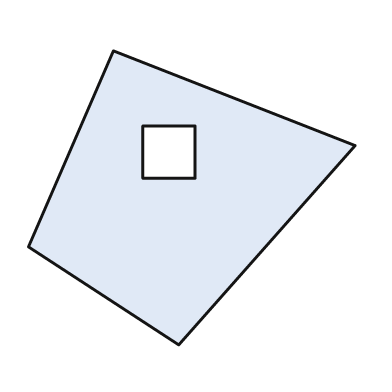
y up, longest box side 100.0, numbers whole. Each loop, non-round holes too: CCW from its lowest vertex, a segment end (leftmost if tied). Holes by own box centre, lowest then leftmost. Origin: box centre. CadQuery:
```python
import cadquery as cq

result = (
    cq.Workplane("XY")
    .moveTo(-4.0, -45.0)
    .lineTo(50.0, 16.0)
    .lineTo(-24.0, 45.0)
    .lineTo(-50.0, -15.0)
    .close()
    .moveTo(-15.0, 6.0)
    .lineTo(1.0, 6.0)
    .lineTo(1.0, 22.0)
    .lineTo(-15.0, 22.0)
    .close()
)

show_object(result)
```